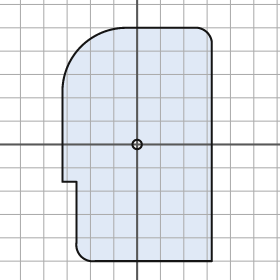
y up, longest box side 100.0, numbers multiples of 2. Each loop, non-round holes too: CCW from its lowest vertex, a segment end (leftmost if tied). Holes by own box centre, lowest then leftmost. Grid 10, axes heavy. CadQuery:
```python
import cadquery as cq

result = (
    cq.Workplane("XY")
    .moveTo(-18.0, -50.0)
    .lineTo(32.0, -50.0)
    .lineTo(32.0, 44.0)
    .threePointArc((30.0, 48.0), (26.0, 50.0))
    .lineTo(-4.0, 50.0)
    .threePointArc((-24.0, 42.0), (-32.0, 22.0))
    .lineTo(-32.0, -16.0)
    .lineTo(-26.0, -16.0)
    .lineTo(-26.0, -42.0)
    .threePointArc((-24.0, -48.0), (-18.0, -50.0))
    .close()
    .moveTo(0.0, 0.0)
    .circle(2.0)
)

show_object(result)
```